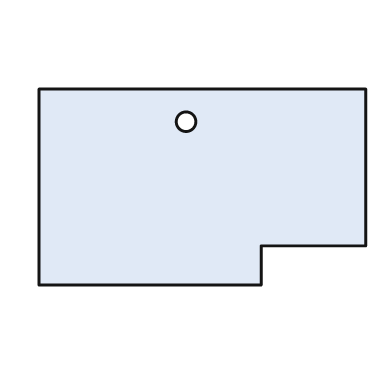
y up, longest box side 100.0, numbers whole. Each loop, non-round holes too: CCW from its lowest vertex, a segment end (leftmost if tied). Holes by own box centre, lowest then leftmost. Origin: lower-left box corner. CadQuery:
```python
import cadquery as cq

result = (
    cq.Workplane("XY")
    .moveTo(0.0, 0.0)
    .lineTo(68.0, 0.0)
    .lineTo(68.0, 12.0)
    .lineTo(100.0, 12.0)
    .lineTo(100.0, 60.0)
    .lineTo(0.0, 60.0)
    .close()
    .moveTo(45.0, 50.0)
    .circle(3.0)
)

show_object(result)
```